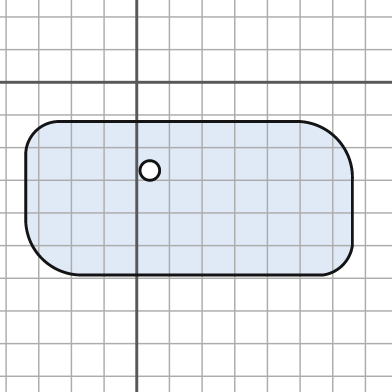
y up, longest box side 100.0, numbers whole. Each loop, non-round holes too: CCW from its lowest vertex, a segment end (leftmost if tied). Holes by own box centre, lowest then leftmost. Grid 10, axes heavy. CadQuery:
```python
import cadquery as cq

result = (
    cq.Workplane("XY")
    .moveTo(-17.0, -59.0)
    .lineTo(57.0, -59.0)
    .threePointArc((63.0, -56.0), (66.0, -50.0))
    .lineTo(66.0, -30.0)
    .threePointArc((61.0, -17.0), (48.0, -12.0))
    .lineTo(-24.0, -12.0)
    .threePointArc((-31.0, -15.0), (-34.0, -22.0))
    .lineTo(-34.0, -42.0)
    .threePointArc((-29.0, -54.0), (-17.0, -59.0))
    .close()
    .moveTo(4.0, -27.0)
    .circle(3.0)
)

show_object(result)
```